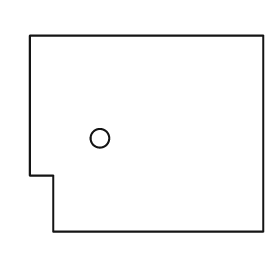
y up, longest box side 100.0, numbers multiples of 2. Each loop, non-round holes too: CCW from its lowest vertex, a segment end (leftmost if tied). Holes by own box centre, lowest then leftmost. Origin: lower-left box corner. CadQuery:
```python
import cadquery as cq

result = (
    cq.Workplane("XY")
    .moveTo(10.0, 0.0)
    .lineTo(100.0, 0.0)
    .lineTo(100.0, 84.0)
    .lineTo(0.0, 84.0)
    .lineTo(0.0, 24.0)
    .lineTo(10.0, 24.0)
    .close()
    .moveTo(30.0, 40.0)
    .circle(4.0)
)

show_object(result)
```